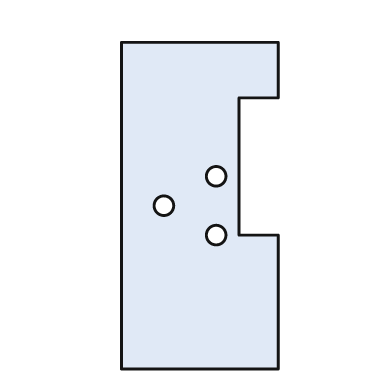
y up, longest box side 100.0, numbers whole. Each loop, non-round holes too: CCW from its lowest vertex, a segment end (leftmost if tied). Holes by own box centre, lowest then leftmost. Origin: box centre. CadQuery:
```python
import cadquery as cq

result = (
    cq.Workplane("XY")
    .moveTo(-24.0, -50.0)
    .lineTo(24.0, -50.0)
    .lineTo(24.0, -9.0)
    .lineTo(12.0, -9.0)
    .lineTo(12.0, 33.0)
    .lineTo(24.0, 33.0)
    .lineTo(24.0, 50.0)
    .lineTo(-24.0, 50.0)
    .close()
    .moveTo(5.0, -9.0)
    .circle(3.0)
    .moveTo(-11.0, 0.0)
    .circle(3.0)
    .moveTo(5.0, 9.0)
    .circle(3.0)
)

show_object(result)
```